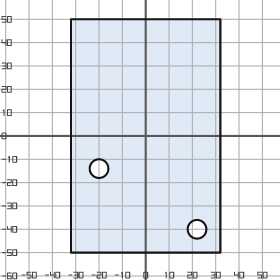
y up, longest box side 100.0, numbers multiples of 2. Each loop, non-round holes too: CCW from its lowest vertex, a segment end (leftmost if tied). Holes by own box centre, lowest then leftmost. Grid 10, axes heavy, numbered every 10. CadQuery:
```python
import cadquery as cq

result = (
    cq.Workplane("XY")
    .moveTo(-32.0, -50.0)
    .lineTo(32.0, -50.0)
    .lineTo(32.0, 50.0)
    .lineTo(-32.0, 50.0)
    .close()
    .moveTo(22.0, -40.0)
    .circle(4.0)
    .moveTo(-20.0, -14.0)
    .circle(4.0)
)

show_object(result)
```